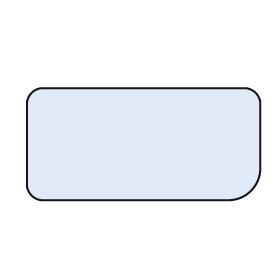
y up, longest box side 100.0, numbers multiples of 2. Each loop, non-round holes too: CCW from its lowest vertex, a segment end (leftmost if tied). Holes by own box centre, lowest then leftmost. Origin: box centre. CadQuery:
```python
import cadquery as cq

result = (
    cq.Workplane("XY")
    .moveTo(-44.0, -24.0)
    .lineTo(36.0, -24.0)
    .threePointArc((46.0, -20.0), (50.0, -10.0))
    .lineTo(50.0, 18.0)
    .threePointArc((48.0, 22.0), (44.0, 24.0))
    .lineTo(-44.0, 24.0)
    .threePointArc((-48.0, 22.0), (-50.0, 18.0))
    .lineTo(-50.0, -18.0)
    .threePointArc((-48.0, -22.0), (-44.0, -24.0))
    .close()
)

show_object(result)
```